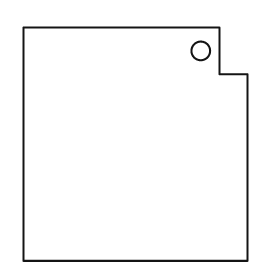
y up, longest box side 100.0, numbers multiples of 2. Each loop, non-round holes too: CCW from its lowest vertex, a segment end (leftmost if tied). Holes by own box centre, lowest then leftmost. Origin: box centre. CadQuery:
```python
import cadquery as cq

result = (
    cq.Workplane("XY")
    .moveTo(-48.0, -50.0)
    .lineTo(48.0, -50.0)
    .lineTo(48.0, 30.0)
    .lineTo(36.0, 30.0)
    .lineTo(36.0, 50.0)
    .lineTo(-48.0, 50.0)
    .close()
    .moveTo(28.0, 40.0)
    .circle(4.0)
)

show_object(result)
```